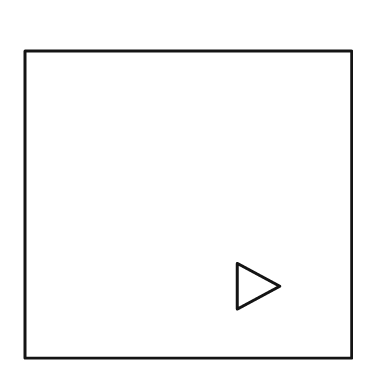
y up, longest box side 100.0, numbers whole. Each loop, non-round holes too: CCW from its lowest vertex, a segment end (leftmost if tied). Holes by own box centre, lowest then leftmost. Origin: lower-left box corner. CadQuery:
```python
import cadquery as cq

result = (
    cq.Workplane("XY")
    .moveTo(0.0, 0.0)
    .lineTo(100.0, 0.0)
    .lineTo(100.0, 94.0)
    .lineTo(0.0, 94.0)
    .close()
    .moveTo(65.0, 15.0)
    .lineTo(78.0, 22.0)
    .lineTo(65.0, 29.0)
    .close()
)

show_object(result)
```